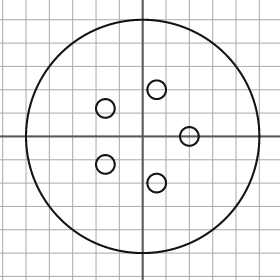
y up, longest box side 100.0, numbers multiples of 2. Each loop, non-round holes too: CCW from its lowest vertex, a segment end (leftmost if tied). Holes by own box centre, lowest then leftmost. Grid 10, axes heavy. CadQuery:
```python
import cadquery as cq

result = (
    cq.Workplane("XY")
    .moveTo(0.0, 0.0)
    .circle(50.0)
    .moveTo(6.0, -20.0)
    .circle(4.0)
    .moveTo(-16.0, -12.0)
    .circle(4.0)
    .moveTo(20.0, 0.0)
    .circle(4.0)
    .moveTo(-16.0, 12.0)
    .circle(4.0)
    .moveTo(6.0, 20.0)
    .circle(4.0)
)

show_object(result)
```